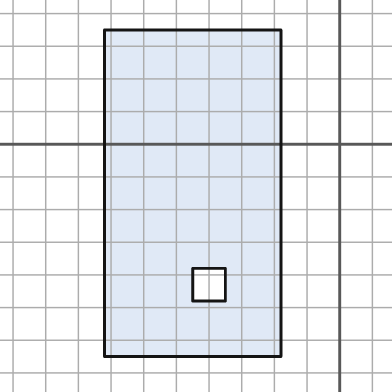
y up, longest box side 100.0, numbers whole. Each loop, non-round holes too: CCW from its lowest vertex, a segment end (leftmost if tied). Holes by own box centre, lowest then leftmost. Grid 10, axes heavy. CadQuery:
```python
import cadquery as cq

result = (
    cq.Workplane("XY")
    .moveTo(-72.0, -65.0)
    .lineTo(-18.0, -65.0)
    .lineTo(-18.0, 35.0)
    .lineTo(-72.0, 35.0)
    .close()
    .moveTo(-45.0, -48.0)
    .lineTo(-35.0, -48.0)
    .lineTo(-35.0, -38.0)
    .lineTo(-45.0, -38.0)
    .close()
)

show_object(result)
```